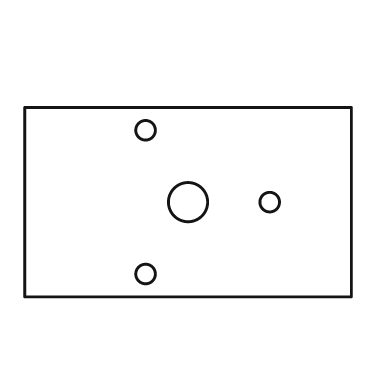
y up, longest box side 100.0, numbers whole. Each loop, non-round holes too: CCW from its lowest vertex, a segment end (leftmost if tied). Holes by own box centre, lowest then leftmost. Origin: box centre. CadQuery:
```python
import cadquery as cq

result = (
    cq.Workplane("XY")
    .moveTo(-50.0, -29.0)
    .lineTo(50.0, -29.0)
    .lineTo(50.0, 29.0)
    .lineTo(-50.0, 29.0)
    .close()
    .moveTo(-13.0, -22.0)
    .circle(3.0)
    .moveTo(0.0, 0.0)
    .circle(6.0)
    .moveTo(25.0, 0.0)
    .circle(3.0)
    .moveTo(-13.0, 22.0)
    .circle(3.0)
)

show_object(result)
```